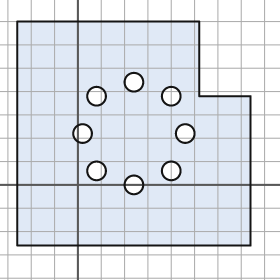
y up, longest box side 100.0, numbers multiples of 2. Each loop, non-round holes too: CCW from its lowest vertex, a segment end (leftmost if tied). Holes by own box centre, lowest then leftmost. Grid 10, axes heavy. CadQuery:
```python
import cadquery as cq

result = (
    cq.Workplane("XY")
    .moveTo(-26.0, -26.0)
    .lineTo(74.0, -26.0)
    .lineTo(74.0, 38.0)
    .lineTo(52.0, 38.0)
    .lineTo(52.0, 70.0)
    .lineTo(-26.0, 70.0)
    .close()
    .moveTo(24.0, 0.0)
    .circle(4.0)
    .moveTo(8.0, 6.0)
    .circle(4.0)
    .moveTo(40.0, 6.0)
    .circle(4.0)
    .moveTo(2.0, 22.0)
    .circle(4.0)
    .moveTo(46.0, 22.0)
    .circle(4.0)
    .moveTo(8.0, 38.0)
    .circle(4.0)
    .moveTo(40.0, 38.0)
    .circle(4.0)
    .moveTo(24.0, 44.0)
    .circle(4.0)
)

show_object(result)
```